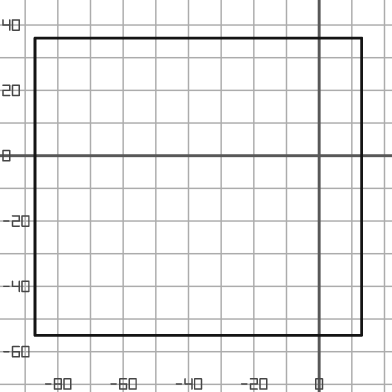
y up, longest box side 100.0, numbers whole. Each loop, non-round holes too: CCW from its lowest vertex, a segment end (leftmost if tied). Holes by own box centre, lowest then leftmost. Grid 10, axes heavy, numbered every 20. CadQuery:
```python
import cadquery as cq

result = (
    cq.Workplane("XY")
    .moveTo(-87.0, -55.0)
    .lineTo(13.0, -55.0)
    .lineTo(13.0, 36.0)
    .lineTo(-87.0, 36.0)
    .close()
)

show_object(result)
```